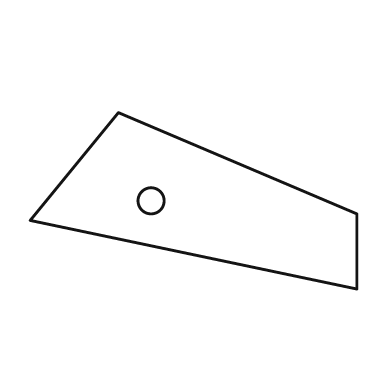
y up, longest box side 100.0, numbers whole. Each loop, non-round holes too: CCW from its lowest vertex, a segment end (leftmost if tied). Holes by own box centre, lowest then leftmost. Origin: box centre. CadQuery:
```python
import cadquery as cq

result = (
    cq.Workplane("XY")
    .moveTo(50.0, -27.0)
    .lineTo(50.0, -4.0)
    .lineTo(-23.0, 27.0)
    .lineTo(-50.0, -6.0)
    .close()
    .moveTo(-13.0, 0.0)
    .circle(4.0)
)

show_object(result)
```